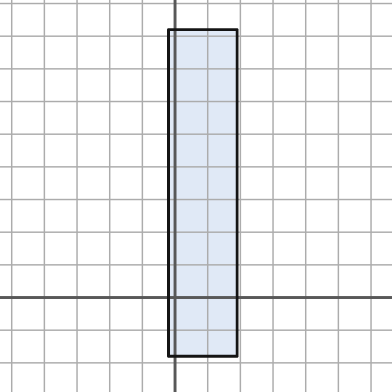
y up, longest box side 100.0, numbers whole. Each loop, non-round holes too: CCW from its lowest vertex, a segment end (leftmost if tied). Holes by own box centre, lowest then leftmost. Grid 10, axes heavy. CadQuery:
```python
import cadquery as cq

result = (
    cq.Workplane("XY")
    .moveTo(-2.0, -18.0)
    .lineTo(19.0, -18.0)
    .lineTo(19.0, 82.0)
    .lineTo(-2.0, 82.0)
    .close()
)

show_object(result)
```